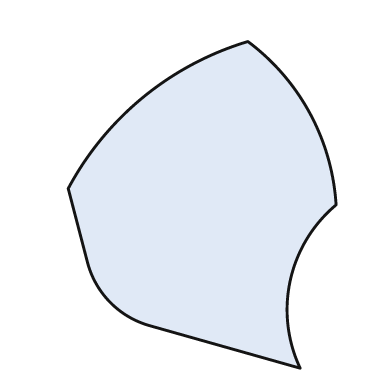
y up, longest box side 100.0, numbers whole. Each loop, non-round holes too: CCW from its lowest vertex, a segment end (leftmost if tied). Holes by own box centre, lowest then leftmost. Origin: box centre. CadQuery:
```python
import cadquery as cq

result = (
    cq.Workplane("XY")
    .moveTo(30.0, -50.0)
    .threePointArc((27.0, -23.0), (41.0, 0.0))
    .threePointArc((33.0, 28.0), (14.0, 50.0))
    .threePointArc((-18.0, 33.0), (-41.0, 5.0))
    .lineTo(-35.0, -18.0)
    .threePointArc((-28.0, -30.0), (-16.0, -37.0))
    .close()
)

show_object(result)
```